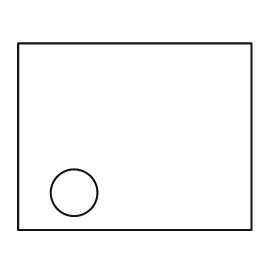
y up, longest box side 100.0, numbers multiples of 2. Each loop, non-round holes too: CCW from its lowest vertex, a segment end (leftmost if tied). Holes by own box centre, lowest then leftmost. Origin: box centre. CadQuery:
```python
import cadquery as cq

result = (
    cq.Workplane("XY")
    .moveTo(-50.0, -40.0)
    .lineTo(50.0, -40.0)
    .lineTo(50.0, 40.0)
    .lineTo(-50.0, 40.0)
    .close()
    .moveTo(-26.0, -24.0)
    .circle(10.0)
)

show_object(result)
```